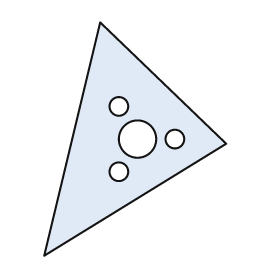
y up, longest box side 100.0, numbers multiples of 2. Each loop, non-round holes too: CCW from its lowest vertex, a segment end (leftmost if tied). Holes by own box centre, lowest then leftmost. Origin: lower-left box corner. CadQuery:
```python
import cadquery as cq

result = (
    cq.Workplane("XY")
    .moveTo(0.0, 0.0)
    .lineTo(78.0, 48.0)
    .lineTo(24.0, 100.0)
    .close()
    .moveTo(32.0, 36.0)
    .circle(4.0)
    .moveTo(40.0, 50.0)
    .circle(8.0)
    .moveTo(56.0, 50.0)
    .circle(4.0)
    .moveTo(32.0, 64.0)
    .circle(4.0)
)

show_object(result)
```